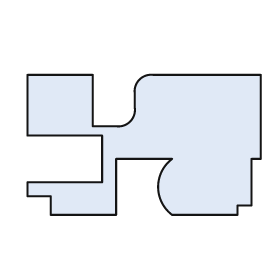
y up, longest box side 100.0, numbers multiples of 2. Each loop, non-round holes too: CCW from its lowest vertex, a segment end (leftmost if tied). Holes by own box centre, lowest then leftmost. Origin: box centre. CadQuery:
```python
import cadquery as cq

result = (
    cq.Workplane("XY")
    .moveTo(-40.0, -30.0)
    .lineTo(-12.0, -30.0)
    .lineTo(-12.0, -6.0)
    .lineTo(12.0, -6.0)
    .threePointArc((6.0, -18.0), (12.0, -30.0))
    .lineTo(40.0, -30.0)
    .lineTo(40.0, -26.0)
    .lineTo(46.0, -26.0)
    .lineTo(46.0, -6.0)
    .lineTo(50.0, -6.0)
    .lineTo(50.0, 30.0)
    .lineTo(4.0, 30.0)
    .threePointArc((-2.0, 28.0), (-4.0, 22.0))
    .lineTo(-4.0, 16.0)
    .threePointArc((-6.0, 10.0), (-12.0, 8.0))
    .lineTo(-22.0, 8.0)
    .lineTo(-22.0, 30.0)
    .lineTo(-50.0, 30.0)
    .lineTo(-50.0, 4.0)
    .lineTo(-18.0, 4.0)
    .lineTo(-18.0, -16.0)
    .lineTo(-50.0, -16.0)
    .lineTo(-50.0, -22.0)
    .lineTo(-40.0, -22.0)
    .close()
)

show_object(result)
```